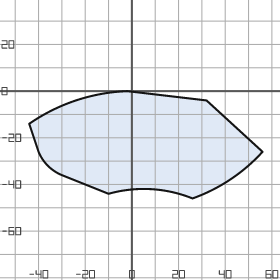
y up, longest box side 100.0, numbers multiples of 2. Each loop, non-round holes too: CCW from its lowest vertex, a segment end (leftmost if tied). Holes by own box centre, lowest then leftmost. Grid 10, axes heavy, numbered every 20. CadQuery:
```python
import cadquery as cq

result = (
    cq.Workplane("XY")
    .moveTo(26.0, -46.0)
    .threePointArc((42.0, -38.0), (56.0, -26.0))
    .lineTo(32.0, -4.0)
    .lineTo(-2.0, 0.0)
    .threePointArc((-24.0, -4.0), (-44.0, -14.0))
    .lineTo(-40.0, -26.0)
    .threePointArc((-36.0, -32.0), (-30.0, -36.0))
    .lineTo(-10.0, -44.0)
    .threePointArc((8.0, -42.0), (26.0, -46.0))
    .close()
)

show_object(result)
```